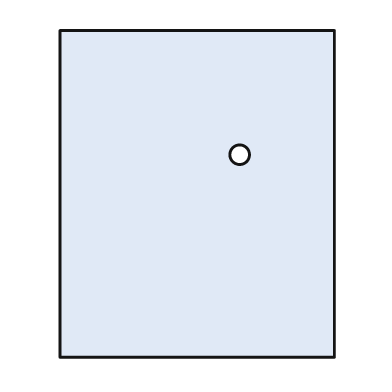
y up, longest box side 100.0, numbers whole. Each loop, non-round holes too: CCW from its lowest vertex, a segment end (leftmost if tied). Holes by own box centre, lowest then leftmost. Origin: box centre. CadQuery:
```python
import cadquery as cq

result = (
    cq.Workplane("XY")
    .moveTo(-42.0, -50.0)
    .lineTo(42.0, -50.0)
    .lineTo(42.0, 50.0)
    .lineTo(-42.0, 50.0)
    .close()
    .moveTo(13.0, 12.0)
    .circle(3.0)
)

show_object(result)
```